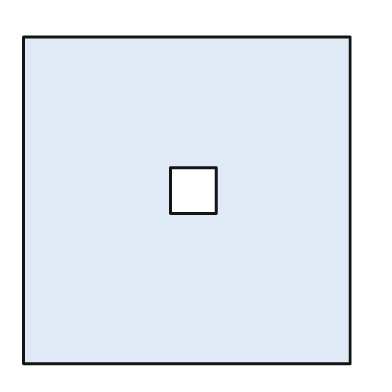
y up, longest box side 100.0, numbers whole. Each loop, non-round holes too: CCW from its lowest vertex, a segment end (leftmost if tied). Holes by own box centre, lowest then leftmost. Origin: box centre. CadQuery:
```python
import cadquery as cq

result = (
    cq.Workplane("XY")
    .moveTo(-50.0, -50.0)
    .lineTo(50.0, -50.0)
    .lineTo(50.0, 50.0)
    .lineTo(-50.0, 50.0)
    .close()
    .moveTo(-5.0, -4.0)
    .lineTo(9.0, -4.0)
    .lineTo(9.0, 10.0)
    .lineTo(-5.0, 10.0)
    .close()
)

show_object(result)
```